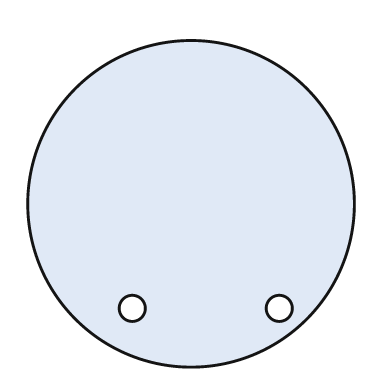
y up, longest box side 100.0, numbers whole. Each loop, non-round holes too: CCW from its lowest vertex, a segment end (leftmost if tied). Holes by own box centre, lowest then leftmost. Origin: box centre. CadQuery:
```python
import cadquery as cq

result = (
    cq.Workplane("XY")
    .moveTo(0.0, 0.0)
    .circle(50.0)
    .moveTo(-18.0, -32.0)
    .circle(4.0)
    .moveTo(27.0, -32.0)
    .circle(4.0)
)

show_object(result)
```